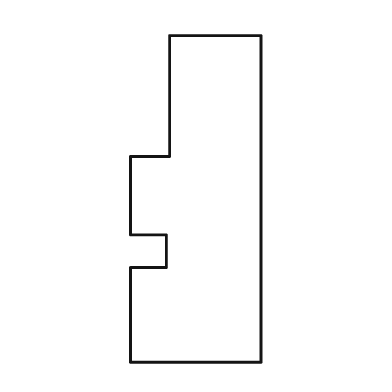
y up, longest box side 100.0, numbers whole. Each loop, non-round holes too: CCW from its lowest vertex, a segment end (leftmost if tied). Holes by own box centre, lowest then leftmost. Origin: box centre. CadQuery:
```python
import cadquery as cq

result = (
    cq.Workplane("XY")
    .moveTo(-20.0, -50.0)
    .lineTo(20.0, -50.0)
    .lineTo(20.0, 50.0)
    .lineTo(-8.0, 50.0)
    .lineTo(-8.0, 13.0)
    .lineTo(-20.0, 13.0)
    .lineTo(-20.0, -11.0)
    .lineTo(-9.0, -11.0)
    .lineTo(-9.0, -21.0)
    .lineTo(-20.0, -21.0)
    .close()
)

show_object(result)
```